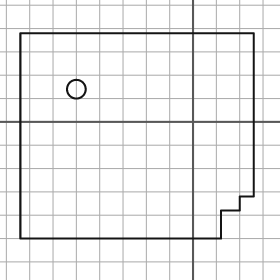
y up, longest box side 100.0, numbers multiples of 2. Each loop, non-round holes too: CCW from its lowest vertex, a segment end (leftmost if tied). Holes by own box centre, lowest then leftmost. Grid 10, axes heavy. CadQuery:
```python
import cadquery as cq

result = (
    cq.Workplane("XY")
    .moveTo(-74.0, -50.0)
    .lineTo(12.0, -50.0)
    .lineTo(12.0, -38.0)
    .lineTo(20.0, -38.0)
    .lineTo(20.0, -32.0)
    .lineTo(26.0, -32.0)
    .lineTo(26.0, 38.0)
    .lineTo(-74.0, 38.0)
    .close()
    .moveTo(-50.0, 14.0)
    .circle(4.0)
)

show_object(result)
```